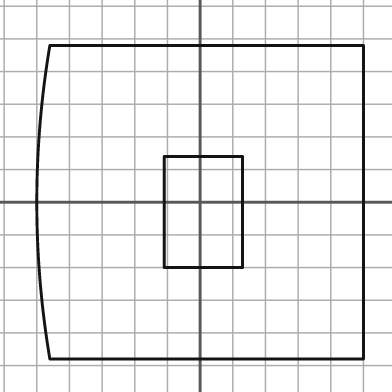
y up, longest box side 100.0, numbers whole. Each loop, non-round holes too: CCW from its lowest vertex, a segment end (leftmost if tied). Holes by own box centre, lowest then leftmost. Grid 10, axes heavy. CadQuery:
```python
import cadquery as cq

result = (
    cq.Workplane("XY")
    .moveTo(-46.0, -48.0)
    .lineTo(50.0, -48.0)
    .lineTo(50.0, 48.0)
    .lineTo(-46.0, 48.0)
    .threePointArc((-50.0, 0.0), (-46.0, -48.0))
    .close()
    .moveTo(-11.0, -20.0)
    .lineTo(13.0, -20.0)
    .lineTo(13.0, 14.0)
    .lineTo(-11.0, 14.0)
    .close()
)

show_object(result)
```